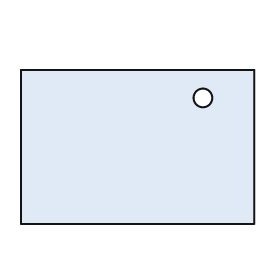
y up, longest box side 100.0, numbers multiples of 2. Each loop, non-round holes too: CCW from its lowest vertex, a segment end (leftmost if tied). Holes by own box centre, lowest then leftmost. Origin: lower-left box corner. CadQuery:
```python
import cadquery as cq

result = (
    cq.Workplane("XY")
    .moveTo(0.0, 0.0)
    .lineTo(100.0, 0.0)
    .lineTo(100.0, 66.0)
    .lineTo(0.0, 66.0)
    .close()
    .moveTo(78.0, 54.0)
    .circle(4.0)
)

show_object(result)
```